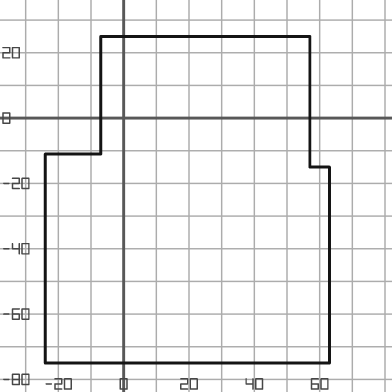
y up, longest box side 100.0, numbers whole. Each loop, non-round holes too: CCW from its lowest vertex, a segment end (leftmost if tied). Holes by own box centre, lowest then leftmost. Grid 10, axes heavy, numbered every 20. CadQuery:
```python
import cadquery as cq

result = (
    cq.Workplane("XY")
    .moveTo(-24.0, -75.0)
    .lineTo(63.0, -75.0)
    .lineTo(63.0, -15.0)
    .lineTo(57.0, -15.0)
    .lineTo(57.0, 25.0)
    .lineTo(-7.0, 25.0)
    .lineTo(-7.0, -11.0)
    .lineTo(-24.0, -11.0)
    .close()
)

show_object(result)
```